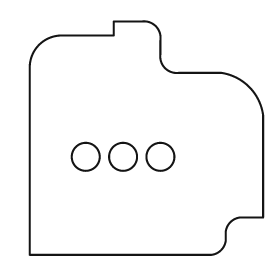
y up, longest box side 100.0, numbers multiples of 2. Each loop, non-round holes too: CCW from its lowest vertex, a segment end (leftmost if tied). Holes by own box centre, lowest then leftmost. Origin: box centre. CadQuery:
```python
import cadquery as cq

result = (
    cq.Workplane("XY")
    .moveTo(-50.0, -50.0)
    .lineTo(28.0, -50.0)
    .threePointArc((32.0, -48.0), (34.0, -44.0))
    .lineTo(34.0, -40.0)
    .threePointArc((36.0, -36.0), (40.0, -34.0))
    .lineTo(50.0, -34.0)
    .lineTo(50.0, 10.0)
    .threePointArc((44.0, 22.0), (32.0, 28.0))
    .lineTo(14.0, 28.0)
    .threePointArc((8.0, 30.0), (6.0, 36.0))
    .lineTo(6.0, 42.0)
    .threePointArc((4.0, 48.0), (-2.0, 50.0))
    .lineTo(-14.0, 50.0)
    .lineTo(-14.0, 44.0)
    .lineTo(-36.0, 44.0)
    .threePointArc((-46.0, 40.0), (-50.0, 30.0))
    .close()
    .moveTo(-26.0, -8.0)
    .circle(6.0)
    .moveTo(-10.0, -8.0)
    .circle(6.0)
    .moveTo(6.0, -8.0)
    .circle(6.0)
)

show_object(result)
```